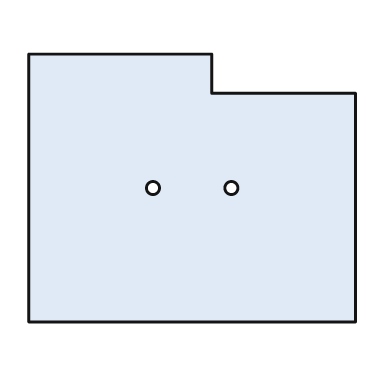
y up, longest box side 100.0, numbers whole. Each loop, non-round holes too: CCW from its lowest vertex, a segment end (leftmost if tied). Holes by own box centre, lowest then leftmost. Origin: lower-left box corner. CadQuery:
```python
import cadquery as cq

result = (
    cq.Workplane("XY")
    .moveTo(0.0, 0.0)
    .lineTo(100.0, 0.0)
    .lineTo(100.0, 70.0)
    .lineTo(56.0, 70.0)
    .lineTo(56.0, 82.0)
    .lineTo(0.0, 82.0)
    .close()
    .moveTo(38.0, 41.0)
    .circle(2.0)
    .moveTo(62.0, 41.0)
    .circle(2.0)
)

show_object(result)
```